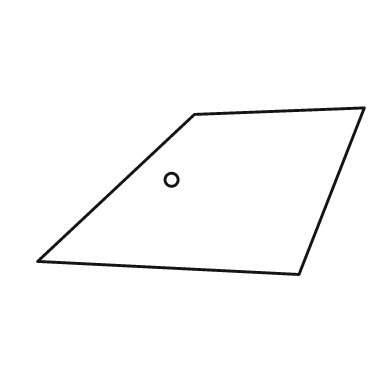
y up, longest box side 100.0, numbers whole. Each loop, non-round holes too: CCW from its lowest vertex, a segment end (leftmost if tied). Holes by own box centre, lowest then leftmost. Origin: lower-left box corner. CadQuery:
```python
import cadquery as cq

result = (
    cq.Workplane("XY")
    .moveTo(80.0, 0.0)
    .lineTo(100.0, 51.0)
    .lineTo(48.0, 49.0)
    .lineTo(0.0, 4.0)
    .close()
    .moveTo(41.0, 29.0)
    .circle(2.0)
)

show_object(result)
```